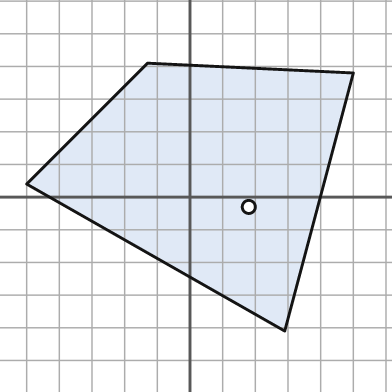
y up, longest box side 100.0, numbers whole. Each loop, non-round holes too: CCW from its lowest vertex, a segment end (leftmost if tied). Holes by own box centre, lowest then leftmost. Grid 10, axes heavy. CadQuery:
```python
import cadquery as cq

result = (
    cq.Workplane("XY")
    .moveTo(29.0, -41.0)
    .lineTo(50.0, 38.0)
    .lineTo(-13.0, 41.0)
    .lineTo(-50.0, 4.0)
    .close()
    .moveTo(18.0, -3.0)
    .circle(2.0)
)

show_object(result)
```